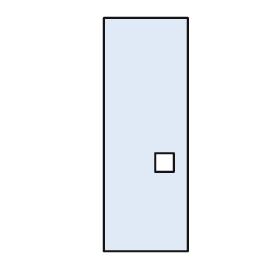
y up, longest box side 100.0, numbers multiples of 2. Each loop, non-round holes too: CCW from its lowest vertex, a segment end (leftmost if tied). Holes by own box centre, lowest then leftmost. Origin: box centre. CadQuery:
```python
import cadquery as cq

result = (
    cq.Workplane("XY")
    .moveTo(-18.0, -50.0)
    .lineTo(18.0, -50.0)
    .lineTo(18.0, 50.0)
    .lineTo(-18.0, 50.0)
    .close()
    .moveTo(4.0, -16.0)
    .lineTo(12.0, -16.0)
    .lineTo(12.0, -8.0)
    .lineTo(4.0, -8.0)
    .close()
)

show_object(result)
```